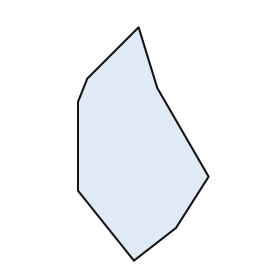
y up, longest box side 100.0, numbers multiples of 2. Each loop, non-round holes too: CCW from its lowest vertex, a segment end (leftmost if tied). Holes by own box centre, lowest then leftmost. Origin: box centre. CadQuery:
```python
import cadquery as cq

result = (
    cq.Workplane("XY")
    .moveTo(-4.0, -50.0)
    .lineTo(14.0, -36.0)
    .lineTo(28.0, -14.0)
    .lineTo(6.0, 24.0)
    .lineTo(-2.0, 50.0)
    .lineTo(-24.0, 28.0)
    .lineTo(-28.0, 18.0)
    .lineTo(-28.0, -20.0)
    .close()
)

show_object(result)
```